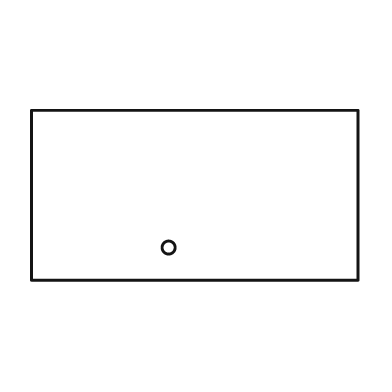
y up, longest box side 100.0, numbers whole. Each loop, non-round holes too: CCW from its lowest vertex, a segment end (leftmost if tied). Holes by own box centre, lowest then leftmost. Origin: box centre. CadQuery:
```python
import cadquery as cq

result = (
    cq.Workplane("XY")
    .moveTo(-50.0, -26.0)
    .lineTo(50.0, -26.0)
    .lineTo(50.0, 26.0)
    .lineTo(-50.0, 26.0)
    .close()
    .moveTo(-8.0, -16.0)
    .circle(2.0)
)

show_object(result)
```